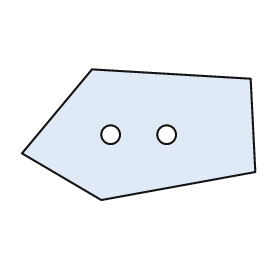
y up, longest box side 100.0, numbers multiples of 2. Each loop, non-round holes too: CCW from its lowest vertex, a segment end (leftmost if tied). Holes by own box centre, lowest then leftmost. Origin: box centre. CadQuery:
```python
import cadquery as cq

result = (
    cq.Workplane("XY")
    .moveTo(-16.0, -28.0)
    .lineTo(50.0, -16.0)
    .lineTo(48.0, 24.0)
    .lineTo(-20.0, 28.0)
    .lineTo(-50.0, -8.0)
    .close()
    .moveTo(-12.0, 0.0)
    .circle(4.0)
    .moveTo(12.0, 0.0)
    .circle(4.0)
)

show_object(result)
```